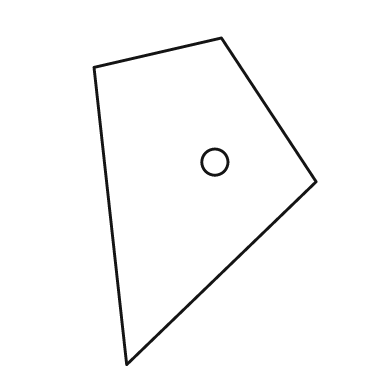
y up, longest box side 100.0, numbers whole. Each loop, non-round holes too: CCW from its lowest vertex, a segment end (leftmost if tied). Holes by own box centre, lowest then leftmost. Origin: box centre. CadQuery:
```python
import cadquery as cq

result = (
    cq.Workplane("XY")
    .moveTo(-24.0, -50.0)
    .lineTo(34.0, 6.0)
    .lineTo(5.0, 50.0)
    .lineTo(-34.0, 41.0)
    .close()
    .moveTo(3.0, 12.0)
    .circle(4.0)
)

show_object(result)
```